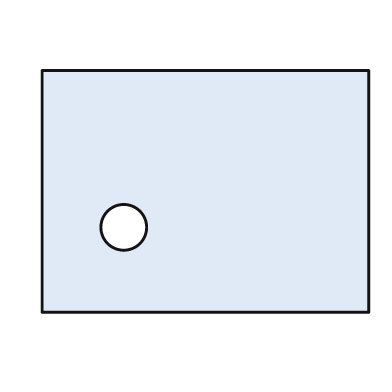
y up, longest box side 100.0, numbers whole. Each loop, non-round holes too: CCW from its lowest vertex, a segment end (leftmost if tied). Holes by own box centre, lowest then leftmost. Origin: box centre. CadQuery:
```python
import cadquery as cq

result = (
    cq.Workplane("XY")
    .moveTo(-50.0, -37.0)
    .lineTo(50.0, -37.0)
    .lineTo(50.0, 37.0)
    .lineTo(-50.0, 37.0)
    .close()
    .moveTo(-25.0, -11.0)
    .circle(7.0)
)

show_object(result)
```